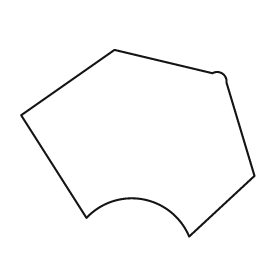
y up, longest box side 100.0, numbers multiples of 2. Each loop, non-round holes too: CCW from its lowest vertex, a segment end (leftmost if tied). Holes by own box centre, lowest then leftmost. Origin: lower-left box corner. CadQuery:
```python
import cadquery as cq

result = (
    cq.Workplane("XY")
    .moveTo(72.0, 0.0)
    .lineTo(100.0, 26.0)
    .lineTo(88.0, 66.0)
    .threePointArc((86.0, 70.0), (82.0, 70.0))
    .lineTo(40.0, 80.0)
    .lineTo(0.0, 52.0)
    .lineTo(28.0, 8.0)
    .threePointArc((52.0, 16.0), (72.0, 0.0))
    .close()
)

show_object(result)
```